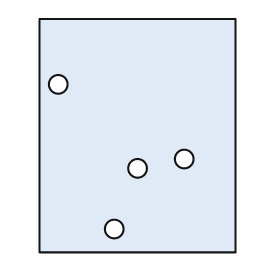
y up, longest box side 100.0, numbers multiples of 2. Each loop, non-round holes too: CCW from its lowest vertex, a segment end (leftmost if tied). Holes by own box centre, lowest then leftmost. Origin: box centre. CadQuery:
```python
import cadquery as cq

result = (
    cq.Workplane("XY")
    .moveTo(-42.0, -50.0)
    .lineTo(42.0, -50.0)
    .lineTo(42.0, 50.0)
    .lineTo(-42.0, 50.0)
    .close()
    .moveTo(-10.0, -40.0)
    .circle(4.0)
    .moveTo(0.0, -14.0)
    .circle(4.0)
    .moveTo(20.0, -10.0)
    .circle(4.0)
    .moveTo(-34.0, 22.0)
    .circle(4.0)
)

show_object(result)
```